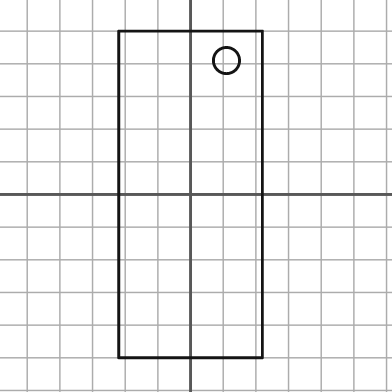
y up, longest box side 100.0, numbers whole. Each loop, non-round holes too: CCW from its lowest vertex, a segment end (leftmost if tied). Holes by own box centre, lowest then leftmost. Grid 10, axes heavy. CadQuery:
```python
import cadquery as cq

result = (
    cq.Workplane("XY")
    .moveTo(-22.0, -50.0)
    .lineTo(22.0, -50.0)
    .lineTo(22.0, 50.0)
    .lineTo(-22.0, 50.0)
    .close()
    .moveTo(11.0, 41.0)
    .circle(4.0)
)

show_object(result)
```